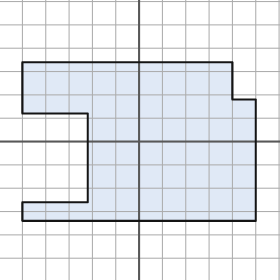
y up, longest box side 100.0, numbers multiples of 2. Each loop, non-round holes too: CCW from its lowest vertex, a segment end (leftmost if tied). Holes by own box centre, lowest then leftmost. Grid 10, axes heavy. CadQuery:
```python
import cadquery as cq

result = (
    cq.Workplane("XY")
    .moveTo(-50.0, -34.0)
    .lineTo(50.0, -34.0)
    .lineTo(50.0, 18.0)
    .lineTo(40.0, 18.0)
    .lineTo(40.0, 34.0)
    .lineTo(-50.0, 34.0)
    .lineTo(-50.0, 12.0)
    .lineTo(-22.0, 12.0)
    .lineTo(-22.0, -26.0)
    .lineTo(-50.0, -26.0)
    .close()
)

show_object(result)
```